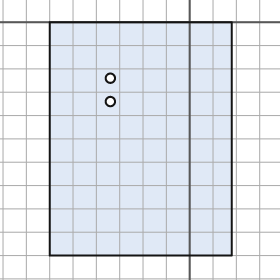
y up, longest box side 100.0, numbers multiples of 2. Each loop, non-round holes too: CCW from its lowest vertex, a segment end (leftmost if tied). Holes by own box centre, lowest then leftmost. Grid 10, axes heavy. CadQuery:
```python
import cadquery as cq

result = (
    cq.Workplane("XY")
    .moveTo(-60.0, -100.0)
    .lineTo(18.0, -100.0)
    .lineTo(18.0, 0.0)
    .lineTo(-60.0, 0.0)
    .close()
    .moveTo(-34.0, -34.0)
    .circle(2.0)
    .moveTo(-34.0, -24.0)
    .circle(2.0)
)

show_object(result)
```